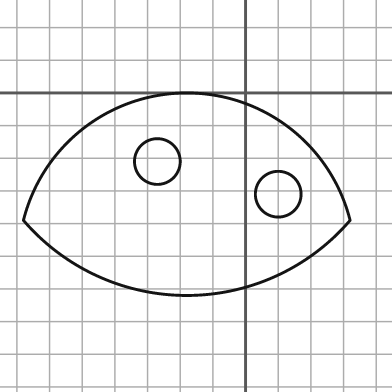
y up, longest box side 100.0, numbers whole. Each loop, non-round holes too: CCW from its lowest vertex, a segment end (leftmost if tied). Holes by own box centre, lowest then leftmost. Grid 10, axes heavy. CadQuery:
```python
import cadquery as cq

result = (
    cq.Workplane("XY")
    .moveTo(-68.0, -39.0)
    .threePointArc((-18.0, -62.0), (32.0, -39.0))
    .threePointArc((-18.0, 0.0), (-68.0, -39.0))
    .close()
    .moveTo(10.0, -31.0)
    .circle(7.0)
    .moveTo(-27.0, -21.0)
    .circle(7.0)
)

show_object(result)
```